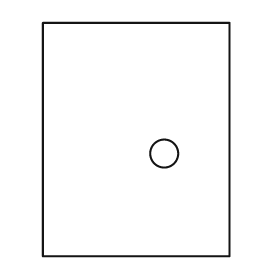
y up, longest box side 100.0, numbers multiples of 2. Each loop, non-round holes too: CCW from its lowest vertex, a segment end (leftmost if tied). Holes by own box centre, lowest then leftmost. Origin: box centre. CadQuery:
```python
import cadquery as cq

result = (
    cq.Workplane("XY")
    .moveTo(-40.0, -50.0)
    .lineTo(40.0, -50.0)
    .lineTo(40.0, 50.0)
    .lineTo(-40.0, 50.0)
    .close()
    .moveTo(12.0, -6.0)
    .circle(6.0)
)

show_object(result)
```